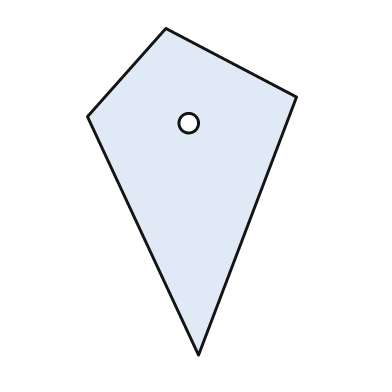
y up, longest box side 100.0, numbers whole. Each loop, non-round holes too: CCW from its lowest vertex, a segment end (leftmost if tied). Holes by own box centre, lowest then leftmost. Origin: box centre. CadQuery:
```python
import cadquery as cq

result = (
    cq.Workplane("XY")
    .moveTo(2.0, -50.0)
    .lineTo(32.0, 29.0)
    .lineTo(-8.0, 50.0)
    .lineTo(-32.0, 23.0)
    .close()
    .moveTo(-1.0, 21.0)
    .circle(3.0)
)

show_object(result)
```